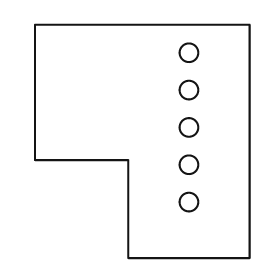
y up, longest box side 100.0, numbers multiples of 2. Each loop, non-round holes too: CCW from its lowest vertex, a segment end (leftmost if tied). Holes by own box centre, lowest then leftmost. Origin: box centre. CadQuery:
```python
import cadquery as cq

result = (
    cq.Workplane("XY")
    .moveTo(-6.0, -50.0)
    .lineTo(46.0, -50.0)
    .lineTo(46.0, 50.0)
    .lineTo(-46.0, 50.0)
    .lineTo(-46.0, -8.0)
    .lineTo(-6.0, -8.0)
    .close()
    .moveTo(20.0, -26.0)
    .circle(4.0)
    .moveTo(20.0, -10.0)
    .circle(4.0)
    .moveTo(20.0, 6.0)
    .circle(4.0)
    .moveTo(20.0, 22.0)
    .circle(4.0)
    .moveTo(20.0, 38.0)
    .circle(4.0)
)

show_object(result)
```